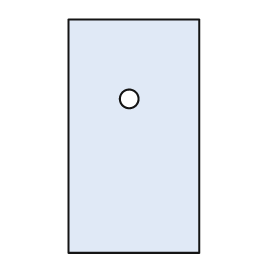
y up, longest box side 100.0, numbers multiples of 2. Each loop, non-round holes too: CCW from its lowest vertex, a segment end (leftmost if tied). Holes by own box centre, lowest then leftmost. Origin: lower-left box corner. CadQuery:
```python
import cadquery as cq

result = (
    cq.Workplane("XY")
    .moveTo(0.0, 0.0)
    .lineTo(56.0, 0.0)
    .lineTo(56.0, 100.0)
    .lineTo(0.0, 100.0)
    .close()
    .moveTo(26.0, 66.0)
    .circle(4.0)
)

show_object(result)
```